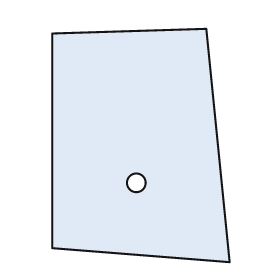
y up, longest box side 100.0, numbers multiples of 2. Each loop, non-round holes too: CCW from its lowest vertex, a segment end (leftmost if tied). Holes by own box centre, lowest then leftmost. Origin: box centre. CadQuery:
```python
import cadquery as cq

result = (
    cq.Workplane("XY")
    .moveTo(38.0, -50.0)
    .lineTo(28.0, 50.0)
    .lineTo(-38.0, 48.0)
    .lineTo(-38.0, -44.0)
    .close()
    .moveTo(-2.0, -16.0)
    .circle(4.0)
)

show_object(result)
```